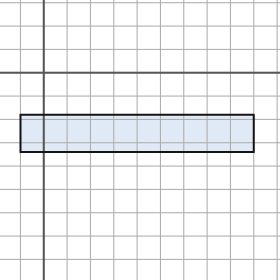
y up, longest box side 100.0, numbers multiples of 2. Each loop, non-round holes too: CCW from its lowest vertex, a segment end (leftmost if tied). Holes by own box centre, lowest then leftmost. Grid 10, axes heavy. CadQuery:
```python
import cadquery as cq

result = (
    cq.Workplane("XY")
    .moveTo(-10.0, -34.0)
    .lineTo(90.0, -34.0)
    .lineTo(90.0, -18.0)
    .lineTo(-10.0, -18.0)
    .close()
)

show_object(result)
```